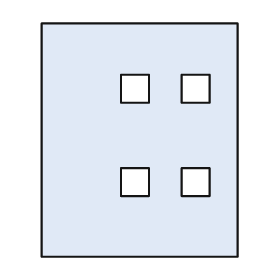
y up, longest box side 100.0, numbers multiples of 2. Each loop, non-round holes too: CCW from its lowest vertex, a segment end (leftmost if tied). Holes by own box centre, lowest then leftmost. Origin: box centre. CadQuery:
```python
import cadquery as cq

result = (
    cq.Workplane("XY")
    .moveTo(-42.0, -50.0)
    .lineTo(42.0, -50.0)
    .lineTo(42.0, 50.0)
    .lineTo(-42.0, 50.0)
    .close()
    .moveTo(-8.0, -24.0)
    .lineTo(4.0, -24.0)
    .lineTo(4.0, -12.0)
    .lineTo(-8.0, -12.0)
    .close()
    .moveTo(18.0, -24.0)
    .lineTo(30.0, -24.0)
    .lineTo(30.0, -12.0)
    .lineTo(18.0, -12.0)
    .close()
    .moveTo(-8.0, 16.0)
    .lineTo(4.0, 16.0)
    .lineTo(4.0, 28.0)
    .lineTo(-8.0, 28.0)
    .close()
    .moveTo(18.0, 16.0)
    .lineTo(30.0, 16.0)
    .lineTo(30.0, 28.0)
    .lineTo(18.0, 28.0)
    .close()
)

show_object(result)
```